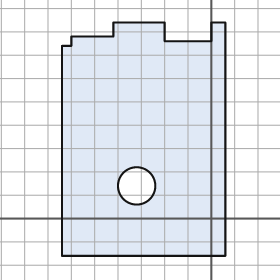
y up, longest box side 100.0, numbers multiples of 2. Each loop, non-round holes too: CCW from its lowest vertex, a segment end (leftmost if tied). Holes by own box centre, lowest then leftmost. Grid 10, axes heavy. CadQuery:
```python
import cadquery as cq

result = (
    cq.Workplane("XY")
    .moveTo(-64.0, -16.0)
    .lineTo(6.0, -16.0)
    .lineTo(6.0, 84.0)
    .lineTo(0.0, 84.0)
    .lineTo(0.0, 76.0)
    .lineTo(-20.0, 76.0)
    .lineTo(-20.0, 84.0)
    .lineTo(-42.0, 84.0)
    .lineTo(-42.0, 78.0)
    .lineTo(-60.0, 78.0)
    .lineTo(-60.0, 74.0)
    .lineTo(-64.0, 74.0)
    .close()
    .moveTo(-32.0, 14.0)
    .circle(8.0)
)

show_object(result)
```